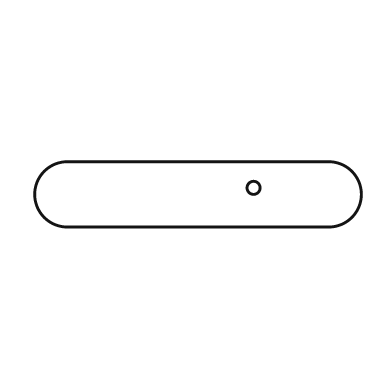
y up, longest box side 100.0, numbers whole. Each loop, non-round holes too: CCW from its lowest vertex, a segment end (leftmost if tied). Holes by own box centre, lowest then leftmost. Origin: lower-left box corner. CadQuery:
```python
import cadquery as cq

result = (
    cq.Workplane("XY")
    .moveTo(10.0, 0.0)
    .lineTo(90.0, 0.0)
    .threePointArc((100.0, 10.0), (90.0, 20.0))
    .lineTo(10.0, 20.0)
    .threePointArc((0.0, 10.0), (10.0, 0.0))
    .close()
    .moveTo(67.0, 12.0)
    .circle(2.0)
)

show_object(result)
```